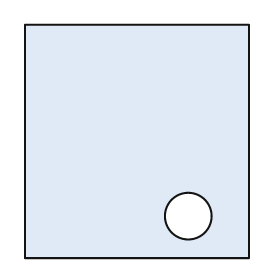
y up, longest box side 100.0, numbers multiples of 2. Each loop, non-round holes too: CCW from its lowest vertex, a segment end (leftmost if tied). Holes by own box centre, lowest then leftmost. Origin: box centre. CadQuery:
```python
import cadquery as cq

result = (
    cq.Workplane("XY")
    .moveTo(-48.0, -50.0)
    .lineTo(48.0, -50.0)
    .lineTo(48.0, 50.0)
    .lineTo(-48.0, 50.0)
    .close()
    .moveTo(22.0, -32.0)
    .circle(10.0)
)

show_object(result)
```